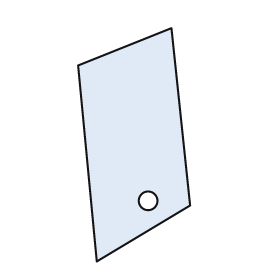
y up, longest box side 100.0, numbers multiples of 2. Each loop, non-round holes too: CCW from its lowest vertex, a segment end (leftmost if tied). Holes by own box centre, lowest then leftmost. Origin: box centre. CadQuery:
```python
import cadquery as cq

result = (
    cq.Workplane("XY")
    .moveTo(-16.0, -50.0)
    .lineTo(24.0, -26.0)
    .lineTo(16.0, 50.0)
    .lineTo(-24.0, 34.0)
    .close()
    .moveTo(6.0, -24.0)
    .circle(4.0)
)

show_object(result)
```